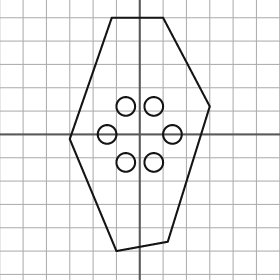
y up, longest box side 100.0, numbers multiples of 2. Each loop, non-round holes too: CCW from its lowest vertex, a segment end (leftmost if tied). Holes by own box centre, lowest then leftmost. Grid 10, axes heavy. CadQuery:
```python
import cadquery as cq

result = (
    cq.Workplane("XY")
    .moveTo(-10.0, -50.0)
    .lineTo(12.0, -46.0)
    .lineTo(30.0, 12.0)
    .lineTo(10.0, 50.0)
    .lineTo(-12.0, 50.0)
    .lineTo(-30.0, -2.0)
    .close()
    .moveTo(-6.0, -12.0)
    .circle(4.0)
    .moveTo(6.0, -12.0)
    .circle(4.0)
    .moveTo(-14.0, 0.0)
    .circle(4.0)
    .moveTo(14.0, 0.0)
    .circle(4.0)
    .moveTo(-6.0, 12.0)
    .circle(4.0)
    .moveTo(6.0, 12.0)
    .circle(4.0)
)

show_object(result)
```